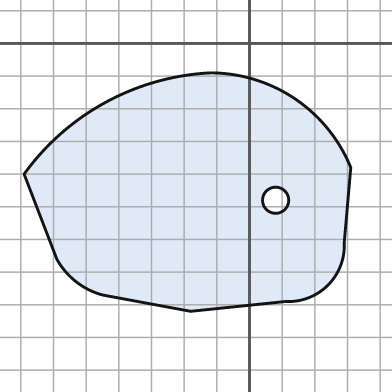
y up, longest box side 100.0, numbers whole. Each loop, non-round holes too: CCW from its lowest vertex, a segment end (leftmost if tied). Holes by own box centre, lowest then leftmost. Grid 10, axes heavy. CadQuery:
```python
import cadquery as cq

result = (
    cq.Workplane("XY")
    .moveTo(-18.0, -82.0)
    .lineTo(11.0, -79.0)
    .threePointArc((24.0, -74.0), (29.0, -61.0))
    .lineTo(31.0, -38.0)
    .threePointArc((14.0, -17.0), (-12.0, -9.0))
    .threePointArc((-44.0, -18.0), (-69.0, -40.0))
    .lineTo(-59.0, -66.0)
    .threePointArc((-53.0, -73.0), (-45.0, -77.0))
    .close()
    .moveTo(8.0, -48.0)
    .circle(4.0)
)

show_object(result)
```